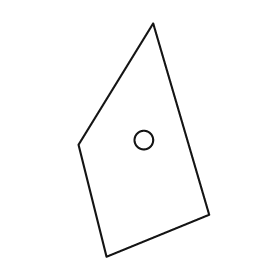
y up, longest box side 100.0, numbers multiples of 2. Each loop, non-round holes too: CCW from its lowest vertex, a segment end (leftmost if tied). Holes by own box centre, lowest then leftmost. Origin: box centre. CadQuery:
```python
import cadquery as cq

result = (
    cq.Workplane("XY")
    .moveTo(-16.0, -50.0)
    .lineTo(28.0, -32.0)
    .lineTo(4.0, 50.0)
    .lineTo(-28.0, -2.0)
    .close()
    .moveTo(0.0, 0.0)
    .circle(4.0)
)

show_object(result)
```